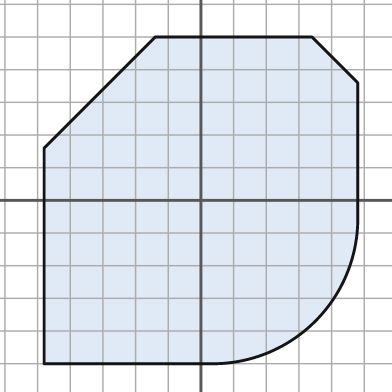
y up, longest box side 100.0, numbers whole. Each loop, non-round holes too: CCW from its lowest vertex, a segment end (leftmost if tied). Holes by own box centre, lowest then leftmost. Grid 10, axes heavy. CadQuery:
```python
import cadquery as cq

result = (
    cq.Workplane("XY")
    .moveTo(-48.0, -50.0)
    .lineTo(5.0, -50.0)
    .threePointArc((35.0, -37.0), (48.0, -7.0))
    .lineTo(48.0, 36.0)
    .lineTo(34.0, 50.0)
    .lineTo(-14.0, 50.0)
    .lineTo(-48.0, 16.0)
    .close()
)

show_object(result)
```